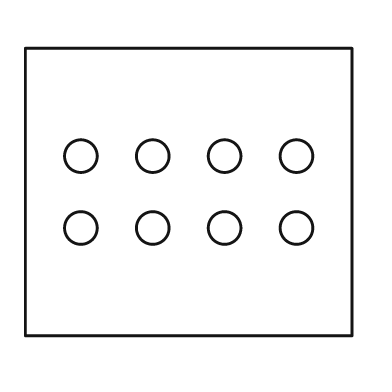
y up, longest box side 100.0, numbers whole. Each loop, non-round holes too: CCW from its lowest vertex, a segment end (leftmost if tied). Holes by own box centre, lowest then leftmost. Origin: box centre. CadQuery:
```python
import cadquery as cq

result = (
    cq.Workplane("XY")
    .moveTo(-50.0, -44.0)
    .lineTo(50.0, -44.0)
    .lineTo(50.0, 44.0)
    .lineTo(-50.0, 44.0)
    .close()
    .moveTo(-33.0, -11.0)
    .circle(5.0)
    .moveTo(-11.0, -11.0)
    .circle(5.0)
    .moveTo(11.0, -11.0)
    .circle(5.0)
    .moveTo(33.0, -11.0)
    .circle(5.0)
    .moveTo(-33.0, 11.0)
    .circle(5.0)
    .moveTo(-11.0, 11.0)
    .circle(5.0)
    .moveTo(11.0, 11.0)
    .circle(5.0)
    .moveTo(33.0, 11.0)
    .circle(5.0)
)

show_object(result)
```